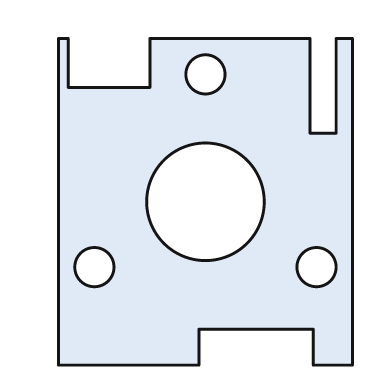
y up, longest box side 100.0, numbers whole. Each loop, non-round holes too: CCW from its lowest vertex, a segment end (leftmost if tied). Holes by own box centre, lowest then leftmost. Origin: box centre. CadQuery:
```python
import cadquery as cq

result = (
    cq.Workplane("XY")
    .moveTo(-45.0, -50.0)
    .lineTo(-2.0, -50.0)
    .lineTo(-2.0, -39.0)
    .lineTo(33.0, -39.0)
    .lineTo(33.0, -50.0)
    .lineTo(45.0, -50.0)
    .lineTo(45.0, 50.0)
    .lineTo(40.0, 50.0)
    .lineTo(40.0, 21.0)
    .lineTo(32.0, 21.0)
    .lineTo(32.0, 50.0)
    .lineTo(-17.0, 50.0)
    .lineTo(-17.0, 35.0)
    .lineTo(-42.0, 35.0)
    .lineTo(-42.0, 50.0)
    .lineTo(-45.0, 50.0)
    .close()
    .moveTo(-34.0, -20.0)
    .circle(6.0)
    .moveTo(34.0, -20.0)
    .circle(6.0)
    .moveTo(0.0, 0.0)
    .circle(18.0)
    .moveTo(0.0, 39.0)
    .circle(6.0)
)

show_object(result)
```